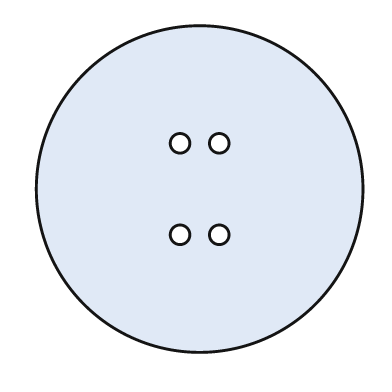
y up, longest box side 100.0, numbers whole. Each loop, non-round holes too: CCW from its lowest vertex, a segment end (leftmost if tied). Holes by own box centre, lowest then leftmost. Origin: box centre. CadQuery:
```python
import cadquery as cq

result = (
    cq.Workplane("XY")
    .moveTo(0.0, 0.0)
    .circle(50.0)
    .moveTo(-6.0, -14.0)
    .circle(3.0)
    .moveTo(6.0, -14.0)
    .circle(3.0)
    .moveTo(-6.0, 14.0)
    .circle(3.0)
    .moveTo(6.0, 14.0)
    .circle(3.0)
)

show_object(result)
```